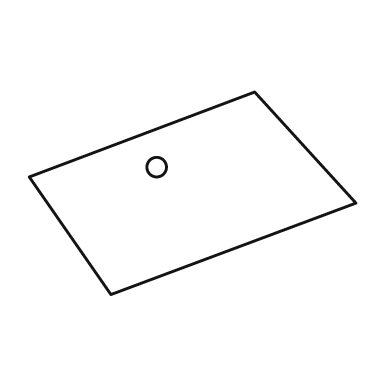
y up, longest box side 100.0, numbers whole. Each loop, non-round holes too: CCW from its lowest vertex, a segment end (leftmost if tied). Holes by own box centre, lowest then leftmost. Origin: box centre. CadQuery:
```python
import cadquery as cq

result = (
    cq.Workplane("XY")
    .moveTo(-25.0, -31.0)
    .lineTo(50.0, -3.0)
    .lineTo(19.0, 31.0)
    .lineTo(-50.0, 5.0)
    .close()
    .moveTo(-11.0, 8.0)
    .circle(3.0)
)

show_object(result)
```